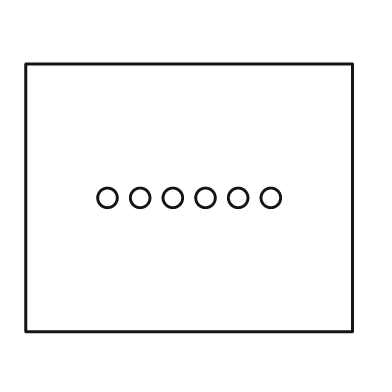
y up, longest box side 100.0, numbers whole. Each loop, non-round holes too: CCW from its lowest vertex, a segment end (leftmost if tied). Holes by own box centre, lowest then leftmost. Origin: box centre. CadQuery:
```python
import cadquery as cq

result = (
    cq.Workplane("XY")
    .moveTo(-50.0, -41.0)
    .lineTo(50.0, -41.0)
    .lineTo(50.0, 41.0)
    .lineTo(-50.0, 41.0)
    .close()
    .moveTo(-25.0, 0.0)
    .circle(3.0)
    .moveTo(-15.0, 0.0)
    .circle(3.0)
    .moveTo(-5.0, 0.0)
    .circle(3.0)
    .moveTo(5.0, 0.0)
    .circle(3.0)
    .moveTo(15.0, 0.0)
    .circle(3.0)
    .moveTo(25.0, 0.0)
    .circle(3.0)
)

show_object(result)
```